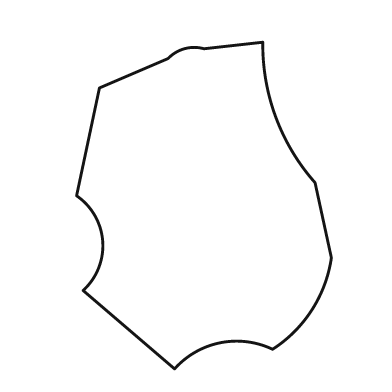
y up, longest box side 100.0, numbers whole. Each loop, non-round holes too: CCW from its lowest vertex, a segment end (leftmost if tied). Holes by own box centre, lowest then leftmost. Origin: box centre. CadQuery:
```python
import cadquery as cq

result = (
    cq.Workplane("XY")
    .moveTo(-9.0, -50.0)
    .threePointArc((5.0, -42.0), (21.0, -44.0))
    .threePointArc((33.0, -32.0), (39.0, -16.0))
    .lineTo(34.0, 7.0)
    .threePointArc((22.0, 27.0), (18.0, 50.0))
    .lineTo(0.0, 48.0)
    .threePointArc((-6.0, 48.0), (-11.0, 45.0))
    .lineTo(-32.0, 36.0)
    .lineTo(-39.0, 3.0)
    .threePointArc((-31.0, -11.0), (-37.0, -26.0))
    .close()
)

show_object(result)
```